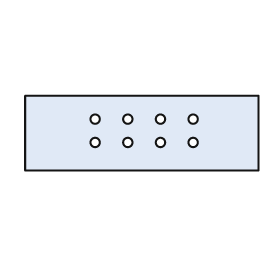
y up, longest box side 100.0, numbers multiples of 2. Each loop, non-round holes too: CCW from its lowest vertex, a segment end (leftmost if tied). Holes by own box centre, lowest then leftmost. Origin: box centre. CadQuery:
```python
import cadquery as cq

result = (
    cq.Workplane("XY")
    .moveTo(-50.0, -16.0)
    .lineTo(50.0, -16.0)
    .lineTo(50.0, 16.0)
    .lineTo(-50.0, 16.0)
    .close()
    .moveTo(-20.0, -4.0)
    .circle(2.0)
    .moveTo(-6.0, -4.0)
    .circle(2.0)
    .moveTo(8.0, -4.0)
    .circle(2.0)
    .moveTo(22.0, -4.0)
    .circle(2.0)
    .moveTo(-20.0, 6.0)
    .circle(2.0)
    .moveTo(-6.0, 6.0)
    .circle(2.0)
    .moveTo(8.0, 6.0)
    .circle(2.0)
    .moveTo(22.0, 6.0)
    .circle(2.0)
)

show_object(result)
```